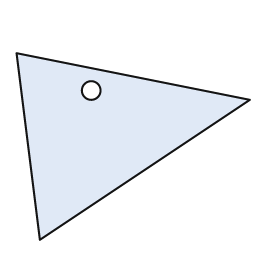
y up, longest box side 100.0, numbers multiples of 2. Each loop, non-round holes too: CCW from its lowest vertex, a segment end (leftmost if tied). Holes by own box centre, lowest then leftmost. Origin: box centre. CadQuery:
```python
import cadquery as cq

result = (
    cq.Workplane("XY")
    .moveTo(-40.0, -40.0)
    .lineTo(50.0, 20.0)
    .lineTo(-50.0, 40.0)
    .close()
    .moveTo(-18.0, 24.0)
    .circle(4.0)
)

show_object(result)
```